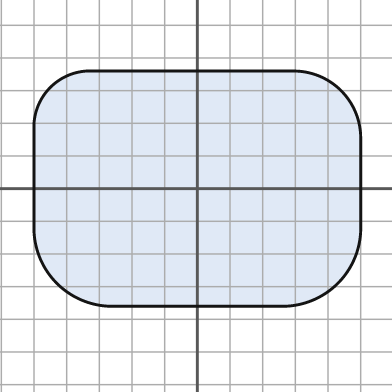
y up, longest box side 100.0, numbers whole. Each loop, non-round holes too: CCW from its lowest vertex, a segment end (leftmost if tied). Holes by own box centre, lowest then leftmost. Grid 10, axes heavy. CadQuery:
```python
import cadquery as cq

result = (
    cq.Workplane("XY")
    .moveTo(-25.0, -36.0)
    .lineTo(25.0, -36.0)
    .threePointArc((43.0, -29.0), (50.0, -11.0))
    .lineTo(50.0, 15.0)
    .threePointArc((44.0, 30.0), (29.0, 36.0))
    .lineTo(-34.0, 36.0)
    .threePointArc((-45.0, 31.0), (-50.0, 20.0))
    .lineTo(-50.0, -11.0)
    .threePointArc((-43.0, -29.0), (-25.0, -36.0))
    .close()
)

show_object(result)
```